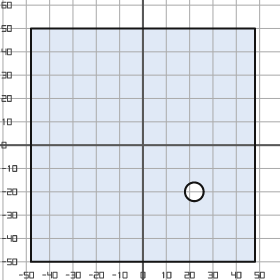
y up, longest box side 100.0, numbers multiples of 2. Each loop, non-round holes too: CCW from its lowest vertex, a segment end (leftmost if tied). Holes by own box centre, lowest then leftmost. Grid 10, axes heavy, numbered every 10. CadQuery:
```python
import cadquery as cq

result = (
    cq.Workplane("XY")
    .moveTo(-48.0, -50.0)
    .lineTo(48.0, -50.0)
    .lineTo(48.0, 50.0)
    .lineTo(-48.0, 50.0)
    .close()
    .moveTo(22.0, -20.0)
    .circle(4.0)
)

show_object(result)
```